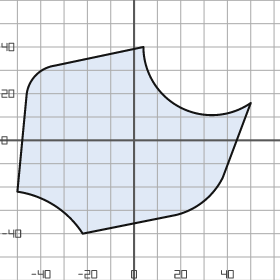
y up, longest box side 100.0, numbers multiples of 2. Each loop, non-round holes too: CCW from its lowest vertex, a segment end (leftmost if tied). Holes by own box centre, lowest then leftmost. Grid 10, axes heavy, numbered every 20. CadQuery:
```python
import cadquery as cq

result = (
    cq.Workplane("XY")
    .moveTo(-22.0, -40.0)
    .lineTo(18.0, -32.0)
    .threePointArc((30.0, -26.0), (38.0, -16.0))
    .lineTo(50.0, 16.0)
    .threePointArc((20.0, 14.0), (4.0, 40.0))
    .lineTo(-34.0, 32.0)
    .threePointArc((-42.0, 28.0), (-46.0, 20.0))
    .lineTo(-50.0, -22.0)
    .threePointArc((-34.0, -28.0), (-22.0, -40.0))
    .close()
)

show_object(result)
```